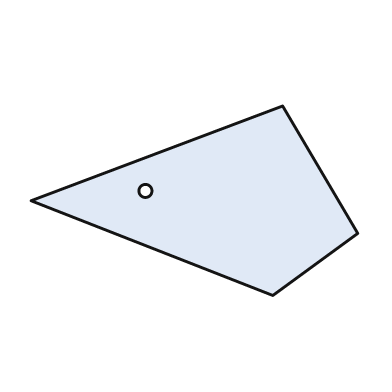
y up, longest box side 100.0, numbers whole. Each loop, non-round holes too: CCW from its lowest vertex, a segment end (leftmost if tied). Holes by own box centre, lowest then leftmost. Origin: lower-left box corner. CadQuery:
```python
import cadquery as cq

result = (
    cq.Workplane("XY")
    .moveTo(74.0, 0.0)
    .lineTo(100.0, 19.0)
    .lineTo(77.0, 58.0)
    .lineTo(0.0, 29.0)
    .close()
    .moveTo(35.0, 32.0)
    .circle(2.0)
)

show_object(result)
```